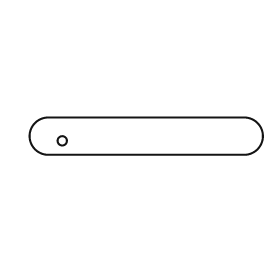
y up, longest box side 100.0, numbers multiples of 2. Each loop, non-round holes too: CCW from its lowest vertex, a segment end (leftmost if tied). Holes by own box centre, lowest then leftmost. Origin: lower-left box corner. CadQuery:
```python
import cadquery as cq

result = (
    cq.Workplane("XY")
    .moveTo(8.0, 0.0)
    .lineTo(92.0, 0.0)
    .threePointArc((100.0, 8.0), (92.0, 16.0))
    .lineTo(8.0, 16.0)
    .threePointArc((0.0, 8.0), (8.0, 0.0))
    .close()
    .moveTo(14.0, 6.0)
    .circle(2.0)
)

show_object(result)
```